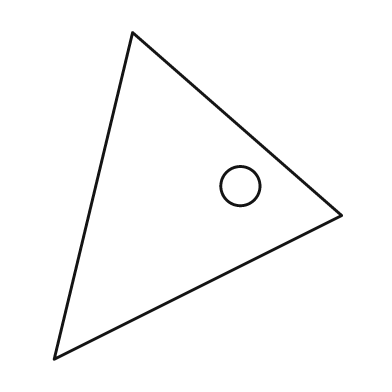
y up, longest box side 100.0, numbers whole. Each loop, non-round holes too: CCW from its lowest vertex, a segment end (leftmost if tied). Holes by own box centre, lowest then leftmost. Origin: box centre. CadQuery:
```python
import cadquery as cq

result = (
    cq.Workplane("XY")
    .moveTo(-44.0, -50.0)
    .lineTo(44.0, -6.0)
    .lineTo(-20.0, 50.0)
    .close()
    .moveTo(13.0, 3.0)
    .circle(6.0)
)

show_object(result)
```